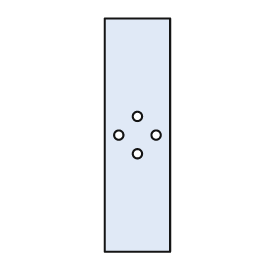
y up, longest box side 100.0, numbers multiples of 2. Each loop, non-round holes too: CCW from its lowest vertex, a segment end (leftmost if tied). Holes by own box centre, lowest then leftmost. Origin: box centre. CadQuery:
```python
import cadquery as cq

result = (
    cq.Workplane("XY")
    .moveTo(-14.0, -50.0)
    .lineTo(14.0, -50.0)
    .lineTo(14.0, 50.0)
    .lineTo(-14.0, 50.0)
    .close()
    .moveTo(0.0, -8.0)
    .circle(2.0)
    .moveTo(-8.0, 0.0)
    .circle(2.0)
    .moveTo(8.0, 0.0)
    .circle(2.0)
    .moveTo(0.0, 8.0)
    .circle(2.0)
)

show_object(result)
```